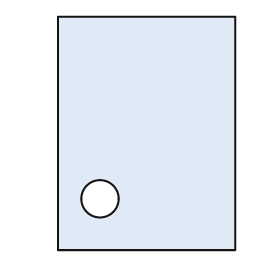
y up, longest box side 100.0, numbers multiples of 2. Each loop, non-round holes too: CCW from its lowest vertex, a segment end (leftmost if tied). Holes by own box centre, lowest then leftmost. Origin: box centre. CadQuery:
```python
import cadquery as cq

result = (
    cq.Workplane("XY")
    .moveTo(-38.0, -50.0)
    .lineTo(38.0, -50.0)
    .lineTo(38.0, 50.0)
    .lineTo(-38.0, 50.0)
    .close()
    .moveTo(-20.0, -28.0)
    .circle(8.0)
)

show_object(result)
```